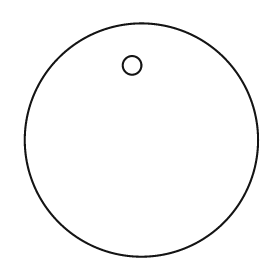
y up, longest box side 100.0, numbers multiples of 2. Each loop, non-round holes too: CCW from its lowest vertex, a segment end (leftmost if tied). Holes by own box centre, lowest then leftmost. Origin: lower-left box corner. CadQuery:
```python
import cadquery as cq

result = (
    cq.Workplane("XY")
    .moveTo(50.0, 50.0)
    .circle(50.0)
    .moveTo(46.0, 82.0)
    .circle(4.0)
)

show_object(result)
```